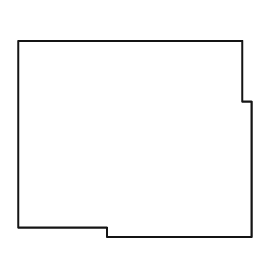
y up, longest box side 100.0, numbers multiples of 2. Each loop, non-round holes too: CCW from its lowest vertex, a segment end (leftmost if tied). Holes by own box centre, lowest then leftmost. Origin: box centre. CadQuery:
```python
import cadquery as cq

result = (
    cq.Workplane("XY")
    .moveTo(-12.0, -42.0)
    .lineTo(50.0, -42.0)
    .lineTo(50.0, 16.0)
    .lineTo(46.0, 16.0)
    .lineTo(46.0, 42.0)
    .lineTo(-50.0, 42.0)
    .lineTo(-50.0, -38.0)
    .lineTo(-12.0, -38.0)
    .close()
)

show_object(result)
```